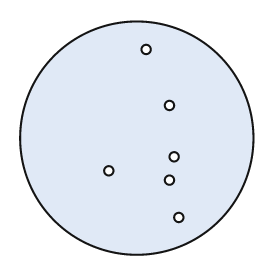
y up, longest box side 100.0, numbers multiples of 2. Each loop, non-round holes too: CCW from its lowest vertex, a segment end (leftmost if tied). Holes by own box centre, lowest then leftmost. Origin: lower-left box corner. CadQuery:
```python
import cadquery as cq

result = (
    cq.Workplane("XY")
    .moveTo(50.0, 50.0)
    .circle(50.0)
    .moveTo(68.0, 16.0)
    .circle(2.0)
    .moveTo(64.0, 32.0)
    .circle(2.0)
    .moveTo(38.0, 36.0)
    .circle(2.0)
    .moveTo(66.0, 42.0)
    .circle(2.0)
    .moveTo(64.0, 64.0)
    .circle(2.0)
    .moveTo(54.0, 88.0)
    .circle(2.0)
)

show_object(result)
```